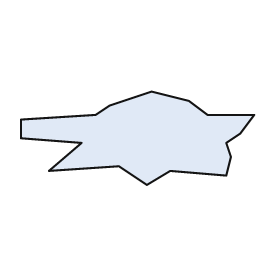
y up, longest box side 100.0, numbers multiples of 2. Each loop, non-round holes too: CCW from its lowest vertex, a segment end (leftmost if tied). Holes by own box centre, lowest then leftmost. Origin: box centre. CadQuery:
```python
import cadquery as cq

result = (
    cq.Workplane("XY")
    .moveTo(4.0, -20.0)
    .lineTo(14.0, -14.0)
    .lineTo(38.0, -16.0)
    .lineTo(40.0, -8.0)
    .lineTo(38.0, -2.0)
    .lineTo(44.0, 2.0)
    .lineTo(50.0, 10.0)
    .lineTo(30.0, 10.0)
    .lineTo(22.0, 16.0)
    .lineTo(6.0, 20.0)
    .lineTo(-12.0, 14.0)
    .lineTo(-18.0, 10.0)
    .lineTo(-50.0, 8.0)
    .lineTo(-50.0, 0.0)
    .lineTo(-24.0, -2.0)
    .lineTo(-38.0, -14.0)
    .lineTo(-8.0, -12.0)
    .close()
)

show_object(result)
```